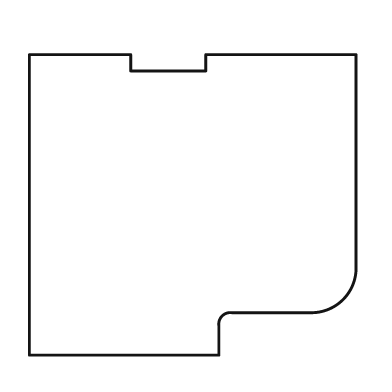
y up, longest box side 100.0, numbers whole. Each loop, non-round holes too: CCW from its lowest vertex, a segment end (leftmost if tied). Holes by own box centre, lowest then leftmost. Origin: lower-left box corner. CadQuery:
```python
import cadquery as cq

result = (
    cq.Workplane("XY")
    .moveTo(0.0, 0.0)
    .lineTo(58.0, 0.0)
    .lineTo(58.0, 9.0)
    .threePointArc((59.0, 12.0), (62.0, 13.0))
    .lineTo(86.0, 13.0)
    .threePointArc((96.0, 17.0), (100.0, 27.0))
    .lineTo(100.0, 92.0)
    .lineTo(54.0, 92.0)
    .lineTo(54.0, 87.0)
    .lineTo(31.0, 87.0)
    .lineTo(31.0, 92.0)
    .lineTo(0.0, 92.0)
    .close()
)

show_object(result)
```